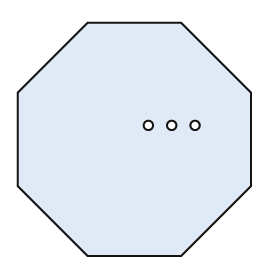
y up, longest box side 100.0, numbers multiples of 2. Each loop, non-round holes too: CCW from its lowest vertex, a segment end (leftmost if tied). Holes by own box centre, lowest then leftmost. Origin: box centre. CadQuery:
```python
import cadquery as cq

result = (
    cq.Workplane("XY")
    .moveTo(-20.0, -50.0)
    .lineTo(20.0, -50.0)
    .lineTo(50.0, -20.0)
    .lineTo(50.0, 20.0)
    .lineTo(20.0, 50.0)
    .lineTo(-20.0, 50.0)
    .lineTo(-50.0, 20.0)
    .lineTo(-50.0, -20.0)
    .close()
    .moveTo(6.0, 6.0)
    .circle(2.0)
    .moveTo(16.0, 6.0)
    .circle(2.0)
    .moveTo(26.0, 6.0)
    .circle(2.0)
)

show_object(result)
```